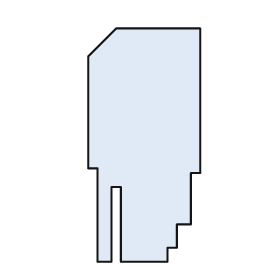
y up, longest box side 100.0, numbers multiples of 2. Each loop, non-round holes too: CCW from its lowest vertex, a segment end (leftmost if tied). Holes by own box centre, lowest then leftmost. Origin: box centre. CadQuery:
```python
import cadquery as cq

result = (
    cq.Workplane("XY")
    .moveTo(-20.0, -50.0)
    .lineTo(-14.0, -50.0)
    .lineTo(-14.0, -18.0)
    .lineTo(-10.0, -18.0)
    .lineTo(-10.0, -50.0)
    .lineTo(10.0, -50.0)
    .lineTo(10.0, -44.0)
    .lineTo(14.0, -44.0)
    .lineTo(14.0, -34.0)
    .lineTo(20.0, -34.0)
    .lineTo(20.0, -12.0)
    .lineTo(24.0, -12.0)
    .lineTo(24.0, 50.0)
    .lineTo(-12.0, 50.0)
    .lineTo(-24.0, 38.0)
    .lineTo(-24.0, -10.0)
    .lineTo(-20.0, -10.0)
    .close()
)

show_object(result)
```